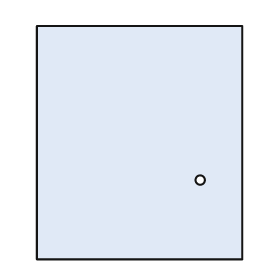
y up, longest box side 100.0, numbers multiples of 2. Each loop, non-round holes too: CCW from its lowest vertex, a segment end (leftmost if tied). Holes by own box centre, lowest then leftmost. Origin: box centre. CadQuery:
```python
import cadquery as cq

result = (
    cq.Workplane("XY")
    .moveTo(-44.0, -50.0)
    .lineTo(44.0, -50.0)
    .lineTo(44.0, 50.0)
    .lineTo(-44.0, 50.0)
    .close()
    .moveTo(26.0, -16.0)
    .circle(2.0)
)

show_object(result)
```